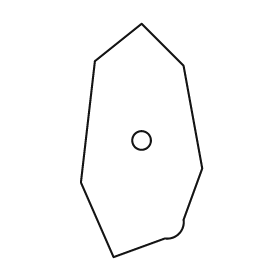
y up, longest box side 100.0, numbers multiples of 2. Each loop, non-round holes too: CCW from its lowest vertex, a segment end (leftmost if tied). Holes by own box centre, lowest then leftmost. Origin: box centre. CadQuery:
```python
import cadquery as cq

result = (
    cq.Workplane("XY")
    .moveTo(-12.0, -50.0)
    .lineTo(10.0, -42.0)
    .threePointArc((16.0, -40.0), (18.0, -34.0))
    .lineTo(26.0, -12.0)
    .lineTo(18.0, 32.0)
    .lineTo(0.0, 50.0)
    .lineTo(-20.0, 34.0)
    .lineTo(-26.0, -18.0)
    .close()
    .moveTo(0.0, 0.0)
    .circle(4.0)
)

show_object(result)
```